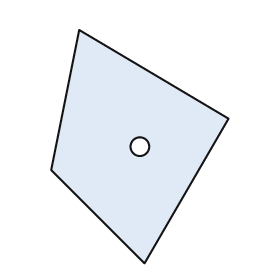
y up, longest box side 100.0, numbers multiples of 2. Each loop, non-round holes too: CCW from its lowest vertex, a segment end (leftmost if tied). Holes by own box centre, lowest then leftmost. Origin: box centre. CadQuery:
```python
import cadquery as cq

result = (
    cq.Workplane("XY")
    .moveTo(2.0, -50.0)
    .lineTo(38.0, 12.0)
    .lineTo(-26.0, 50.0)
    .lineTo(-38.0, -10.0)
    .close()
    .moveTo(0.0, 0.0)
    .circle(4.0)
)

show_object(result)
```